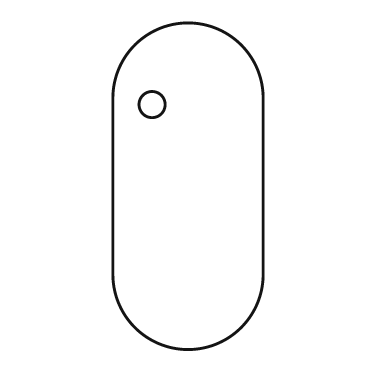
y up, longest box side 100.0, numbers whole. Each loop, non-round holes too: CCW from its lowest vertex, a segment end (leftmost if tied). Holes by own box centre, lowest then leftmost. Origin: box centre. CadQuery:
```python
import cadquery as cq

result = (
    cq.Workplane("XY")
    .moveTo(-23.0, -27.0)
    .threePointArc((0.0, -50.0), (23.0, -27.0))
    .lineTo(23.0, 27.0)
    .threePointArc((0.0, 50.0), (-23.0, 27.0))
    .close()
    .moveTo(-11.0, 25.0)
    .circle(4.0)
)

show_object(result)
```